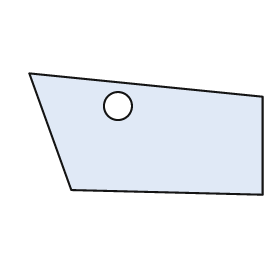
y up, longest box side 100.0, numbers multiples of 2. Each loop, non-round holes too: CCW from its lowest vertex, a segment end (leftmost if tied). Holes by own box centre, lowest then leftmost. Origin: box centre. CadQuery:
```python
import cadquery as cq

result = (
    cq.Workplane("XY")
    .moveTo(50.0, -26.0)
    .lineTo(50.0, 16.0)
    .lineTo(-50.0, 26.0)
    .lineTo(-32.0, -24.0)
    .close()
    .moveTo(-12.0, 12.0)
    .circle(6.0)
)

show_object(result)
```